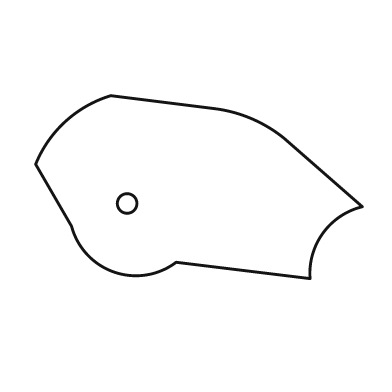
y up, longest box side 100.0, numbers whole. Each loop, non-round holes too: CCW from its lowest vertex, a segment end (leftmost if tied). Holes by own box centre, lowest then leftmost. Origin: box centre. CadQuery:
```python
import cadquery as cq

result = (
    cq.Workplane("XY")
    .moveTo(34.0, -28.0)
    .threePointArc((38.0, -14.0), (50.0, -6.0))
    .lineTo(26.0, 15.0)
    .threePointArc((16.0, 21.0), (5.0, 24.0))
    .lineTo(-27.0, 28.0)
    .threePointArc((-41.0, 20.0), (-50.0, 7.0))
    .lineTo(-39.0, -12.0)
    .threePointArc((-26.0, -26.0), (-7.0, -23.0))
    .close()
    .moveTo(-22.0, -5.0)
    .circle(3.0)
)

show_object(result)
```